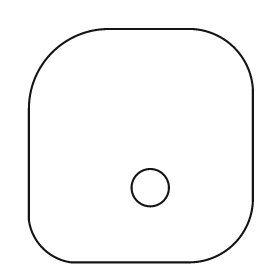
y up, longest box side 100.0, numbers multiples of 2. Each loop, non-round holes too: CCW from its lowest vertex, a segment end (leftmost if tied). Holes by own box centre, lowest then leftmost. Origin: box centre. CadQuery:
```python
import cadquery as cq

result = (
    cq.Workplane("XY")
    .moveTo(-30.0, -50.0)
    .lineTo(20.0, -50.0)
    .threePointArc((40.0, -42.0), (48.0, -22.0))
    .lineTo(48.0, 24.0)
    .threePointArc((40.0, 42.0), (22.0, 50.0))
    .lineTo(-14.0, 50.0)
    .threePointArc((-38.0, 40.0), (-48.0, 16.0))
    .lineTo(-48.0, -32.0)
    .threePointArc((-42.0, -44.0), (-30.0, -50.0))
    .close()
    .moveTo(4.0, -18.0)
    .circle(8.0)
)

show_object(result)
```